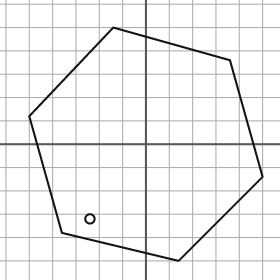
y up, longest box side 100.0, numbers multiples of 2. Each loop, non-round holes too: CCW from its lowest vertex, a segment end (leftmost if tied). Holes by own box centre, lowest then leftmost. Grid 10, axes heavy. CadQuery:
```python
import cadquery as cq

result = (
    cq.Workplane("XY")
    .moveTo(14.0, -50.0)
    .lineTo(50.0, -14.0)
    .lineTo(36.0, 36.0)
    .lineTo(-14.0, 50.0)
    .lineTo(-50.0, 12.0)
    .lineTo(-36.0, -38.0)
    .close()
    .moveTo(-24.0, -32.0)
    .circle(2.0)
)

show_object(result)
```